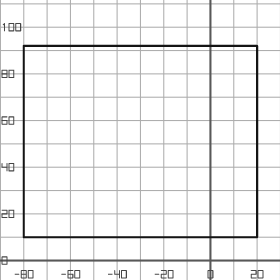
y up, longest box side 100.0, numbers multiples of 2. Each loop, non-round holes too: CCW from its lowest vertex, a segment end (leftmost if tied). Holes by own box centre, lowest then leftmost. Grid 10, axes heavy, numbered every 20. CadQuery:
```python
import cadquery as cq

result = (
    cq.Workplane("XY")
    .moveTo(-80.0, 10.0)
    .lineTo(20.0, 10.0)
    .lineTo(20.0, 92.0)
    .lineTo(-80.0, 92.0)
    .close()
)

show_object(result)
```